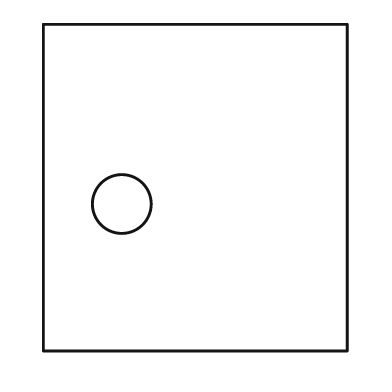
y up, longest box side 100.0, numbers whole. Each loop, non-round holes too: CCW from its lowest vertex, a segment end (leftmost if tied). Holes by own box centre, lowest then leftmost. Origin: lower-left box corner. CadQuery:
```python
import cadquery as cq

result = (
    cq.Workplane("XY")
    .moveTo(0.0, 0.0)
    .lineTo(93.0, 0.0)
    .lineTo(93.0, 100.0)
    .lineTo(0.0, 100.0)
    .close()
    .moveTo(24.0, 45.0)
    .circle(9.0)
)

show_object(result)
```